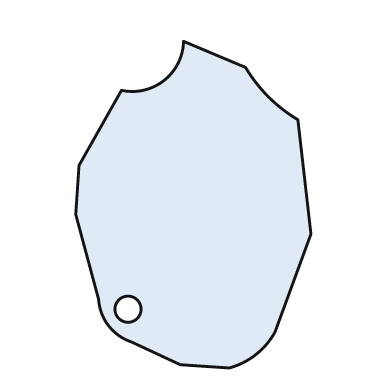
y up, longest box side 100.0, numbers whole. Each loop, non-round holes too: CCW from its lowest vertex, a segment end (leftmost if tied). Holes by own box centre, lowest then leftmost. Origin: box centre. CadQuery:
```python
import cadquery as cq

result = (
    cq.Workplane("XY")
    .moveTo(11.0, -50.0)
    .threePointArc((19.0, -46.0), (25.0, -39.0))
    .lineTo(36.0, -9.0)
    .lineTo(32.0, 26.0)
    .threePointArc((23.0, 33.0), (16.0, 42.0))
    .lineTo(-3.0, 50.0)
    .threePointArc((-9.0, 38.0), (-22.0, 35.0))
    .lineTo(-35.0, 12.0)
    .lineTo(-36.0, -3.0)
    .lineTo(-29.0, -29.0)
    .threePointArc((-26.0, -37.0), (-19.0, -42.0))
    .lineTo(-4.0, -49.0)
    .close()
    .moveTo(-20.0, -32.0)
    .circle(4.0)
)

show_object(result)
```